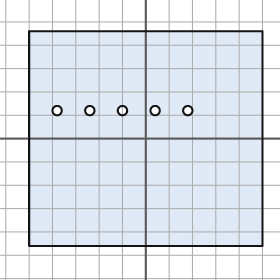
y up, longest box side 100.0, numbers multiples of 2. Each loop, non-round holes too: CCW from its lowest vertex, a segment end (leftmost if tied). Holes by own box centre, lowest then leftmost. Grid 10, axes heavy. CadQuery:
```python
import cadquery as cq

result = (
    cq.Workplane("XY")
    .moveTo(-50.0, -46.0)
    .lineTo(50.0, -46.0)
    .lineTo(50.0, 46.0)
    .lineTo(-50.0, 46.0)
    .close()
    .moveTo(-38.0, 12.0)
    .circle(2.0)
    .moveTo(-24.0, 12.0)
    .circle(2.0)
    .moveTo(-10.0, 12.0)
    .circle(2.0)
    .moveTo(4.0, 12.0)
    .circle(2.0)
    .moveTo(18.0, 12.0)
    .circle(2.0)
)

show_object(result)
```